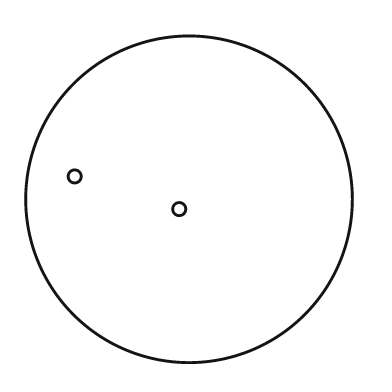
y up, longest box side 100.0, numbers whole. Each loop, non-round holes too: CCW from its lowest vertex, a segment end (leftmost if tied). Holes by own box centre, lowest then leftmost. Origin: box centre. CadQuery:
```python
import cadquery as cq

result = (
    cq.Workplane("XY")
    .moveTo(0.0, 0.0)
    .circle(50.0)
    .moveTo(-3.0, -3.0)
    .circle(2.0)
    .moveTo(-35.0, 7.0)
    .circle(2.0)
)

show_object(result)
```